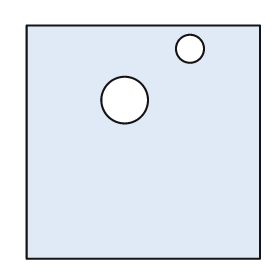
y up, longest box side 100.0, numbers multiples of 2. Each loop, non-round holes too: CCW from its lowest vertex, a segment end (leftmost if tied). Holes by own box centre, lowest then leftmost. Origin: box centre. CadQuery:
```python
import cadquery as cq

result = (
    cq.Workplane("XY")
    .moveTo(-50.0, -50.0)
    .lineTo(50.0, -50.0)
    .lineTo(50.0, 50.0)
    .lineTo(-50.0, 50.0)
    .close()
    .moveTo(-8.0, 18.0)
    .circle(10.0)
    .moveTo(20.0, 40.0)
    .circle(6.0)
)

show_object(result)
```